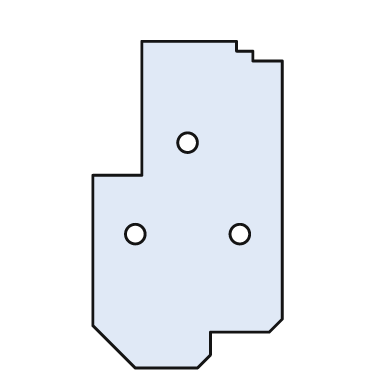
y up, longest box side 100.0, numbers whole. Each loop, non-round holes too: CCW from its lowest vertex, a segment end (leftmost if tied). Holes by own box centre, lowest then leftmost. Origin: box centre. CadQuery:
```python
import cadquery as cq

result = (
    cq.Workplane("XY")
    .moveTo(-16.0, -50.0)
    .lineTo(3.0, -50.0)
    .lineTo(7.0, -46.0)
    .lineTo(7.0, -39.0)
    .lineTo(25.0, -39.0)
    .lineTo(29.0, -35.0)
    .lineTo(29.0, 44.0)
    .lineTo(20.0, 44.0)
    .lineTo(20.0, 47.0)
    .lineTo(15.0, 47.0)
    .lineTo(15.0, 50.0)
    .lineTo(-14.0, 50.0)
    .lineTo(-14.0, 9.0)
    .lineTo(-29.0, 9.0)
    .lineTo(-29.0, -37.0)
    .close()
    .moveTo(-16.0, -9.0)
    .circle(3.0)
    .moveTo(16.0, -9.0)
    .circle(3.0)
    .moveTo(0.0, 19.0)
    .circle(3.0)
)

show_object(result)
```